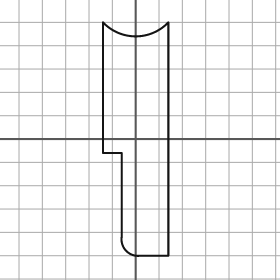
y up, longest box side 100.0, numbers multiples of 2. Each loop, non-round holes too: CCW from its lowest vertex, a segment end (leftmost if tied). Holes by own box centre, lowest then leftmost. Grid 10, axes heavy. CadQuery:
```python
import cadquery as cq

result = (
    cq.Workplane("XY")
    .moveTo(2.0, -50.0)
    .lineTo(14.0, -50.0)
    .lineTo(14.0, 50.0)
    .threePointArc((0.0, 44.0), (-14.0, 50.0))
    .lineTo(-14.0, -6.0)
    .lineTo(-6.0, -6.0)
    .lineTo(-6.0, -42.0)
    .threePointArc((-4.0, -48.0), (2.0, -50.0))
    .close()
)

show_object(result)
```